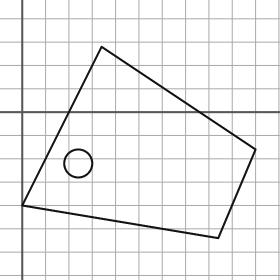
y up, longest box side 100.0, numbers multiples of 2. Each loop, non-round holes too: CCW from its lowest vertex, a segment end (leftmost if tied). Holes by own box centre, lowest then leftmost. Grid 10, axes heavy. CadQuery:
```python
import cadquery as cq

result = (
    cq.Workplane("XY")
    .moveTo(84.0, -54.0)
    .lineTo(100.0, -16.0)
    .lineTo(34.0, 28.0)
    .lineTo(0.0, -40.0)
    .close()
    .moveTo(24.0, -22.0)
    .circle(6.0)
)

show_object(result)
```